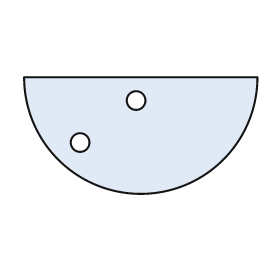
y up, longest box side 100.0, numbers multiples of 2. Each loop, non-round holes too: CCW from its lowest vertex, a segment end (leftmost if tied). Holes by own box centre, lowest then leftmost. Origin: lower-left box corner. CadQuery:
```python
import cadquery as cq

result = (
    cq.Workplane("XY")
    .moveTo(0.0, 50.0)
    .threePointArc((50.0, 0.0), (100.0, 50.0))
    .close()
    .moveTo(24.0, 22.0)
    .circle(4.0)
    .moveTo(48.0, 40.0)
    .circle(4.0)
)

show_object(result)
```